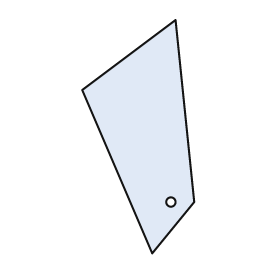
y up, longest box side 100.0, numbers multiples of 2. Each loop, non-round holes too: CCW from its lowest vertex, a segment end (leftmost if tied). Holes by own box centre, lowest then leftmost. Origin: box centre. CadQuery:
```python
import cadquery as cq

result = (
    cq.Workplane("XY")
    .moveTo(6.0, -50.0)
    .lineTo(24.0, -28.0)
    .lineTo(16.0, 50.0)
    .lineTo(-24.0, 20.0)
    .close()
    .moveTo(14.0, -28.0)
    .circle(2.0)
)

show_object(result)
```